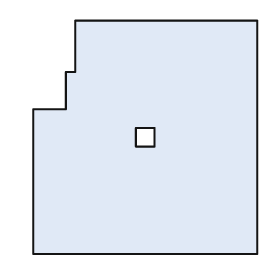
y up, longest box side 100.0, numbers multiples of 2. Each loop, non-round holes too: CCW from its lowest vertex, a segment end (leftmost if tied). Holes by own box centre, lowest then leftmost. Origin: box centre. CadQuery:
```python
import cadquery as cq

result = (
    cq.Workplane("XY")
    .moveTo(-48.0, -50.0)
    .lineTo(48.0, -50.0)
    .lineTo(48.0, 50.0)
    .lineTo(-30.0, 50.0)
    .lineTo(-30.0, 28.0)
    .lineTo(-34.0, 28.0)
    .lineTo(-34.0, 12.0)
    .lineTo(-48.0, 12.0)
    .close()
    .moveTo(-4.0, -4.0)
    .lineTo(4.0, -4.0)
    .lineTo(4.0, 4.0)
    .lineTo(-4.0, 4.0)
    .close()
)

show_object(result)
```